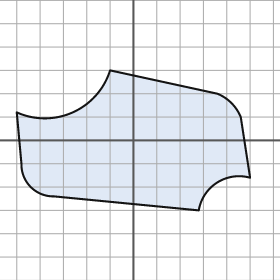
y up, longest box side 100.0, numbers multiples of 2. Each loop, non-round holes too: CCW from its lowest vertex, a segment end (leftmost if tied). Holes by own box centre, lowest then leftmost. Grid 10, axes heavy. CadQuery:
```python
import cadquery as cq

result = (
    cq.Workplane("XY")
    .moveTo(28.0, -30.0)
    .threePointArc((36.0, -18.0), (50.0, -16.0))
    .lineTo(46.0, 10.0)
    .threePointArc((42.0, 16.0), (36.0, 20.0))
    .lineTo(-10.0, 30.0)
    .threePointArc((-26.0, 12.0), (-50.0, 12.0))
    .lineTo(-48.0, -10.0)
    .threePointArc((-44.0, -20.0), (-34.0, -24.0))
    .close()
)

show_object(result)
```